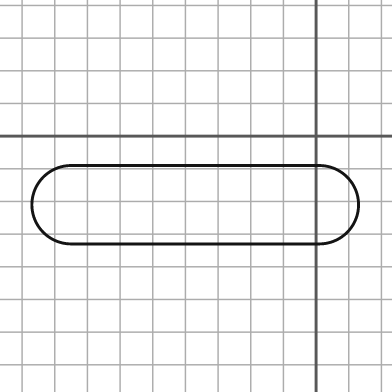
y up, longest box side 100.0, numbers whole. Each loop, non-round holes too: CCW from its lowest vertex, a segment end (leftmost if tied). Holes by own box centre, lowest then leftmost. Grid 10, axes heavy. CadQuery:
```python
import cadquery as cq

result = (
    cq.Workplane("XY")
    .moveTo(-75.0, -33.0)
    .lineTo(1.0, -33.0)
    .threePointArc((13.0, -21.0), (1.0, -9.0))
    .lineTo(-75.0, -9.0)
    .threePointArc((-87.0, -21.0), (-75.0, -33.0))
    .close()
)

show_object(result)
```